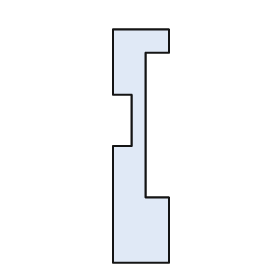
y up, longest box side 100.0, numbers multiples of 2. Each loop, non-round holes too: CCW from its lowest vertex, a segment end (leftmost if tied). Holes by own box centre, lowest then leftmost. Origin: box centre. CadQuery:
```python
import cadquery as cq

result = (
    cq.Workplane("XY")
    .moveTo(-12.0, -50.0)
    .lineTo(12.0, -50.0)
    .lineTo(12.0, -22.0)
    .lineTo(2.0, -22.0)
    .lineTo(2.0, 40.0)
    .lineTo(12.0, 40.0)
    .lineTo(12.0, 50.0)
    .lineTo(-12.0, 50.0)
    .lineTo(-12.0, 22.0)
    .lineTo(-4.0, 22.0)
    .lineTo(-4.0, 0.0)
    .lineTo(-12.0, 0.0)
    .close()
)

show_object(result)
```